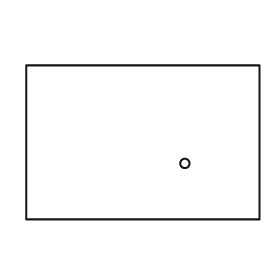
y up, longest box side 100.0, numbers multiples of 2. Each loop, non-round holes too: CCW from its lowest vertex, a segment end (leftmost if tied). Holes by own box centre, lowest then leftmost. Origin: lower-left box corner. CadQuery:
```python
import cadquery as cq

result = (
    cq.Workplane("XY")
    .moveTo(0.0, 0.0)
    .lineTo(100.0, 0.0)
    .lineTo(100.0, 66.0)
    .lineTo(0.0, 66.0)
    .close()
    .moveTo(68.0, 24.0)
    .circle(2.0)
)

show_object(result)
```